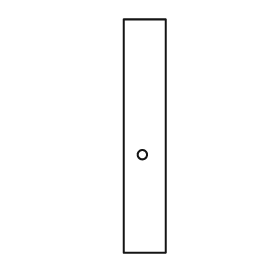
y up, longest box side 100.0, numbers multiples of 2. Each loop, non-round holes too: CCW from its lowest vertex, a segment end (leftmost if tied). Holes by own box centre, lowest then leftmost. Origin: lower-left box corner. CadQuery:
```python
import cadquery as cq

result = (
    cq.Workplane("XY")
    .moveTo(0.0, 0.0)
    .lineTo(18.0, 0.0)
    .lineTo(18.0, 100.0)
    .lineTo(0.0, 100.0)
    .close()
    .moveTo(8.0, 42.0)
    .circle(2.0)
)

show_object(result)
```